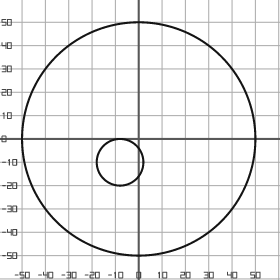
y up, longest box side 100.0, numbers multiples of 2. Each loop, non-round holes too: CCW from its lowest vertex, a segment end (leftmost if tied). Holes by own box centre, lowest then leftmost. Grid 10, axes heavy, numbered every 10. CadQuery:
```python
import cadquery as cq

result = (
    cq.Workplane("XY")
    .moveTo(0.0, 0.0)
    .circle(50.0)
    .moveTo(-8.0, -10.0)
    .circle(10.0)
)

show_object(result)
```